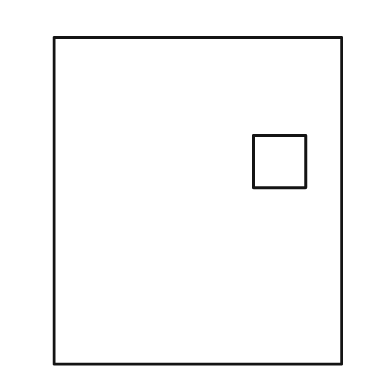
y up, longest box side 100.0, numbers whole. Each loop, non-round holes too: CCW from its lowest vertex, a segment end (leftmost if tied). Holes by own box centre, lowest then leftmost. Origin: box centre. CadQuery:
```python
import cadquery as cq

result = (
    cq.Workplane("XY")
    .moveTo(-44.0, -50.0)
    .lineTo(44.0, -50.0)
    .lineTo(44.0, 50.0)
    .lineTo(-44.0, 50.0)
    .close()
    .moveTo(17.0, 4.0)
    .lineTo(33.0, 4.0)
    .lineTo(33.0, 20.0)
    .lineTo(17.0, 20.0)
    .close()
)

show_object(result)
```